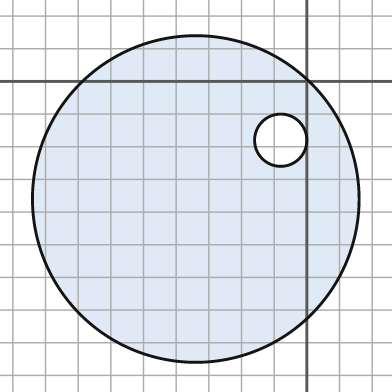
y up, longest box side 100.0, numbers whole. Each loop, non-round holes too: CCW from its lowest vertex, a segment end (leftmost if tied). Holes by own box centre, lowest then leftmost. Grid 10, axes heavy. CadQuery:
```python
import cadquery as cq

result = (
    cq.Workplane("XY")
    .moveTo(-34.0, -36.0)
    .circle(50.0)
    .moveTo(-8.0, -18.0)
    .circle(8.0)
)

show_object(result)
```